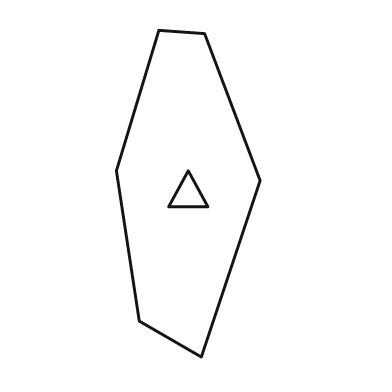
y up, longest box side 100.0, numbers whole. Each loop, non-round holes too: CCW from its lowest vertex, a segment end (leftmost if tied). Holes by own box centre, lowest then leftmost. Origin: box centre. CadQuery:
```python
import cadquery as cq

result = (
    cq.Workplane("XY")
    .moveTo(4.0, -50.0)
    .lineTo(22.0, 4.0)
    .lineTo(5.0, 49.0)
    .lineTo(-9.0, 50.0)
    .lineTo(-22.0, 7.0)
    .lineTo(-15.0, -39.0)
    .close()
    .moveTo(-6.0, -4.0)
    .lineTo(6.0, -4.0)
    .lineTo(0.0, 7.0)
    .close()
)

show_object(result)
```